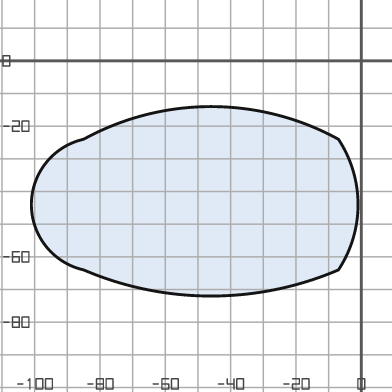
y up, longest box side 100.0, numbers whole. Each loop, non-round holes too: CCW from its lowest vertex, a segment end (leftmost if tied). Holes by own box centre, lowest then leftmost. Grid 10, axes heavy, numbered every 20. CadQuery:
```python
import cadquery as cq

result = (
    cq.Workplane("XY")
    .moveTo(-85.0, -64.0)
    .threePointArc((-46.0, -72.0), (-7.0, -64.0))
    .threePointArc((-1.0, -44.0), (-7.0, -24.0))
    .threePointArc((-46.0, -14.0), (-85.0, -24.0))
    .threePointArc((-101.0, -44.0), (-85.0, -64.0))
    .close()
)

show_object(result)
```